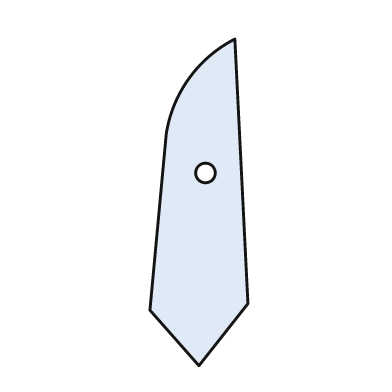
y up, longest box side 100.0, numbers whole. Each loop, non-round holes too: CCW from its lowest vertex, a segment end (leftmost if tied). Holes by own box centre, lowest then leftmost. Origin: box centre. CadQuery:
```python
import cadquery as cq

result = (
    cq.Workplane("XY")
    .moveTo(0.0, -50.0)
    .lineTo(15.0, -31.0)
    .lineTo(11.0, 50.0)
    .threePointArc((-3.0, 38.0), (-10.0, 21.0))
    .lineTo(-15.0, -33.0)
    .close()
    .moveTo(2.0, 9.0)
    .circle(3.0)
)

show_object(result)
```